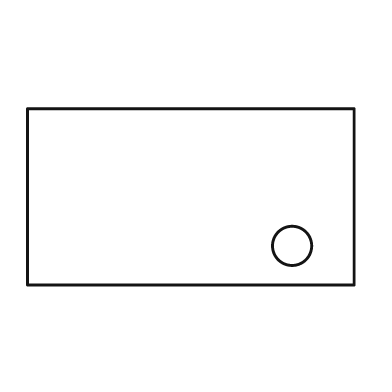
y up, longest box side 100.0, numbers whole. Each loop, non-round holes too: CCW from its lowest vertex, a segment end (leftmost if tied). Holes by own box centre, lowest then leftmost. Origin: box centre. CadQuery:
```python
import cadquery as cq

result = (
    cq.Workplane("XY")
    .moveTo(-50.0, -27.0)
    .lineTo(50.0, -27.0)
    .lineTo(50.0, 27.0)
    .lineTo(-50.0, 27.0)
    .close()
    .moveTo(31.0, -15.0)
    .circle(6.0)
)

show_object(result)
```